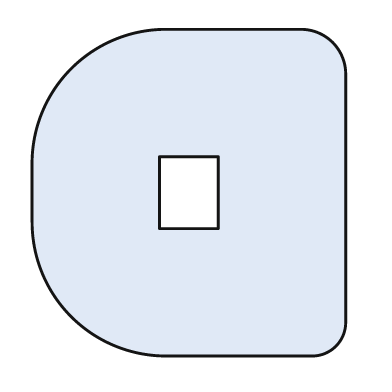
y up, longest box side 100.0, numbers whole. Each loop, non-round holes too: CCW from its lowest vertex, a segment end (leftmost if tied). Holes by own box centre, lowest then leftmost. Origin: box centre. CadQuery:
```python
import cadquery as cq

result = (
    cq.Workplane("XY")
    .moveTo(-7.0, -50.0)
    .lineTo(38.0, -50.0)
    .threePointArc((45.0, -47.0), (48.0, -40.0))
    .lineTo(48.0, 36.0)
    .threePointArc((44.0, 46.0), (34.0, 50.0))
    .lineTo(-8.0, 50.0)
    .threePointArc((-36.0, 38.0), (-48.0, 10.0))
    .lineTo(-48.0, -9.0)
    .threePointArc((-36.0, -38.0), (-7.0, -50.0))
    .close()
    .moveTo(-9.0, -11.0)
    .lineTo(9.0, -11.0)
    .lineTo(9.0, 11.0)
    .lineTo(-9.0, 11.0)
    .close()
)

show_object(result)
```